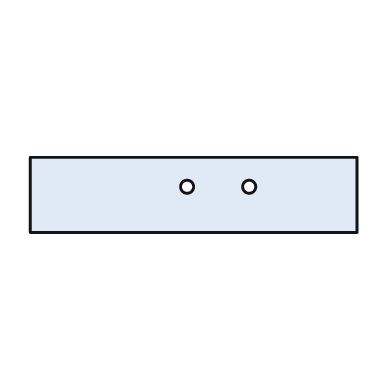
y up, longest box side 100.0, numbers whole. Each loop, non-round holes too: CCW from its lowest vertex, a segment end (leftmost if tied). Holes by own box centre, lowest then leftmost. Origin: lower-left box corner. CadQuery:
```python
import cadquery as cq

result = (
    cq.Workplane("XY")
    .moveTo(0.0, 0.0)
    .lineTo(100.0, 0.0)
    .lineTo(100.0, 23.0)
    .lineTo(0.0, 23.0)
    .close()
    .moveTo(48.0, 14.0)
    .circle(2.0)
    .moveTo(67.0, 14.0)
    .circle(2.0)
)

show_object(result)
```